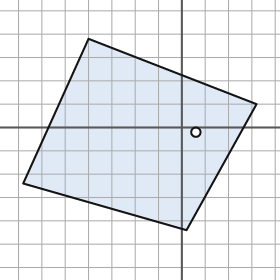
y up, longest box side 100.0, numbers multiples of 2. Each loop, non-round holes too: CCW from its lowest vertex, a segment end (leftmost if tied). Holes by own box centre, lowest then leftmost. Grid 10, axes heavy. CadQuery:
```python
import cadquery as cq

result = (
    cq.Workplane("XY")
    .moveTo(2.0, -44.0)
    .lineTo(32.0, 10.0)
    .lineTo(-40.0, 38.0)
    .lineTo(-68.0, -24.0)
    .close()
    .moveTo(6.0, -2.0)
    .circle(2.0)
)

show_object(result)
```